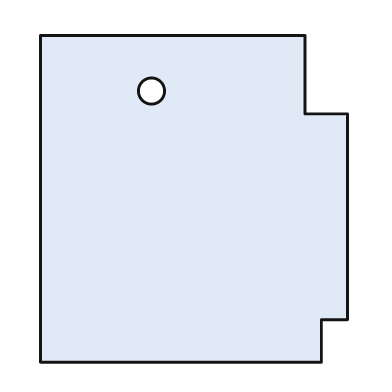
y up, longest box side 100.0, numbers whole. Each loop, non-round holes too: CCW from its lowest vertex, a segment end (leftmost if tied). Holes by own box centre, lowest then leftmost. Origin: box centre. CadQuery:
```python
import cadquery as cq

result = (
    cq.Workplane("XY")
    .moveTo(-47.0, -50.0)
    .lineTo(39.0, -50.0)
    .lineTo(39.0, -37.0)
    .lineTo(47.0, -37.0)
    .lineTo(47.0, 26.0)
    .lineTo(34.0, 26.0)
    .lineTo(34.0, 50.0)
    .lineTo(-47.0, 50.0)
    .close()
    .moveTo(-13.0, 33.0)
    .circle(4.0)
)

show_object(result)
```